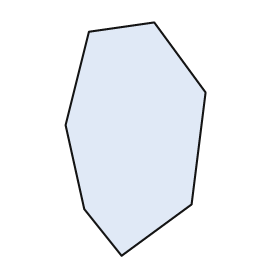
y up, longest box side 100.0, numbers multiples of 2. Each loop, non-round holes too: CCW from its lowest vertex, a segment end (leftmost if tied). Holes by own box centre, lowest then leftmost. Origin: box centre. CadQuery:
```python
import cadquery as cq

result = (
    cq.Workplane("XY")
    .moveTo(-6.0, -50.0)
    .lineTo(24.0, -28.0)
    .lineTo(30.0, 20.0)
    .lineTo(8.0, 50.0)
    .lineTo(-20.0, 46.0)
    .lineTo(-30.0, 6.0)
    .lineTo(-22.0, -30.0)
    .close()
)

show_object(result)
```